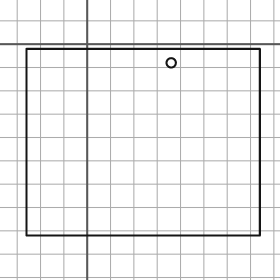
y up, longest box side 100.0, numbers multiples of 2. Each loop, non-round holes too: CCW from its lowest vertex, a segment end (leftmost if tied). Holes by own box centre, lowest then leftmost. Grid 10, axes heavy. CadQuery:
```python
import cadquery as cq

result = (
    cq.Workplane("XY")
    .moveTo(-26.0, -82.0)
    .lineTo(74.0, -82.0)
    .lineTo(74.0, -2.0)
    .lineTo(-26.0, -2.0)
    .close()
    .moveTo(36.0, -8.0)
    .circle(2.0)
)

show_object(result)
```